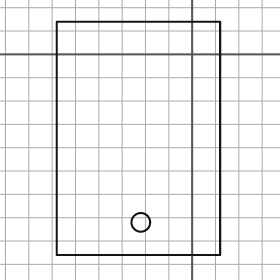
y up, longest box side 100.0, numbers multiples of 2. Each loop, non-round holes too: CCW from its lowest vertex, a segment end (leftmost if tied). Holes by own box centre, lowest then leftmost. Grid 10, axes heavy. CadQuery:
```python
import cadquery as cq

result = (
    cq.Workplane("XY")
    .moveTo(-58.0, -86.0)
    .lineTo(12.0, -86.0)
    .lineTo(12.0, 14.0)
    .lineTo(-58.0, 14.0)
    .close()
    .moveTo(-22.0, -72.0)
    .circle(4.0)
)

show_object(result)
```